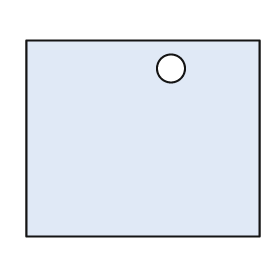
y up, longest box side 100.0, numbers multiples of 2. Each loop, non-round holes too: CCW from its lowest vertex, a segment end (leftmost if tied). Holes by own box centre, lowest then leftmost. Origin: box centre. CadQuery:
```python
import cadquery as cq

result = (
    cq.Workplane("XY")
    .moveTo(-50.0, -42.0)
    .lineTo(50.0, -42.0)
    .lineTo(50.0, 42.0)
    .lineTo(-50.0, 42.0)
    .close()
    .moveTo(12.0, 30.0)
    .circle(6.0)
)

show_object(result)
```